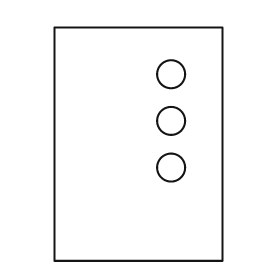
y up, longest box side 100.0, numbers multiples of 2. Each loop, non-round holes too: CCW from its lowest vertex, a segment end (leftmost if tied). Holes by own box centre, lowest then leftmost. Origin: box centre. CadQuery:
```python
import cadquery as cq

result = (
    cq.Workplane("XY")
    .moveTo(-36.0, -50.0)
    .lineTo(36.0, -50.0)
    .lineTo(36.0, 50.0)
    .lineTo(-36.0, 50.0)
    .close()
    .moveTo(14.0, -10.0)
    .circle(6.0)
    .moveTo(14.0, 10.0)
    .circle(6.0)
    .moveTo(14.0, 30.0)
    .circle(6.0)
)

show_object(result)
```